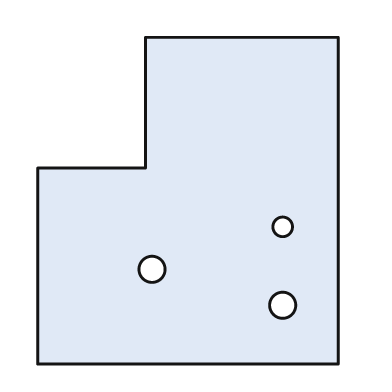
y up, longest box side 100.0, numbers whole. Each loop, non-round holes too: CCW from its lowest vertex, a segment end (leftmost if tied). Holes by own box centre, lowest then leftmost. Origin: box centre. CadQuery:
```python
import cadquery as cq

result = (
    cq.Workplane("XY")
    .moveTo(-46.0, -50.0)
    .lineTo(46.0, -50.0)
    .lineTo(46.0, 50.0)
    .lineTo(-13.0, 50.0)
    .lineTo(-13.0, 10.0)
    .lineTo(-46.0, 10.0)
    .close()
    .moveTo(29.0, -32.0)
    .circle(4.0)
    .moveTo(-11.0, -21.0)
    .circle(4.0)
    .moveTo(29.0, -8.0)
    .circle(3.0)
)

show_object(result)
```